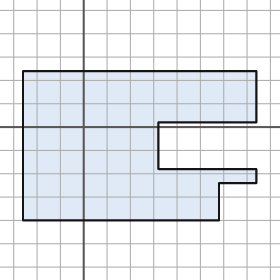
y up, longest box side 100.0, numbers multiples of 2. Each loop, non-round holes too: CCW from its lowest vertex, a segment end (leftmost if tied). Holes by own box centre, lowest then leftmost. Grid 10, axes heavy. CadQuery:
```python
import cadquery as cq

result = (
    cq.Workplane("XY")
    .moveTo(-26.0, -40.0)
    .lineTo(58.0, -40.0)
    .lineTo(58.0, -24.0)
    .lineTo(74.0, -24.0)
    .lineTo(74.0, -18.0)
    .lineTo(32.0, -18.0)
    .lineTo(32.0, 2.0)
    .lineTo(74.0, 2.0)
    .lineTo(74.0, 24.0)
    .lineTo(-26.0, 24.0)
    .close()
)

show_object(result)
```